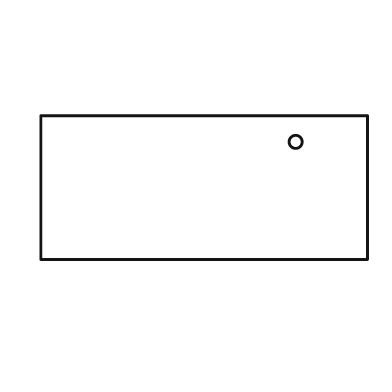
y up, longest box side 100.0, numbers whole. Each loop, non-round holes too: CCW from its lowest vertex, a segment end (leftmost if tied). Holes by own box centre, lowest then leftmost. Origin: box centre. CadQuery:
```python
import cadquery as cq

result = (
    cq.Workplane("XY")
    .moveTo(-50.0, -22.0)
    .lineTo(50.0, -22.0)
    .lineTo(50.0, 22.0)
    .lineTo(-50.0, 22.0)
    .close()
    .moveTo(28.0, 14.0)
    .circle(2.0)
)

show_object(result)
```